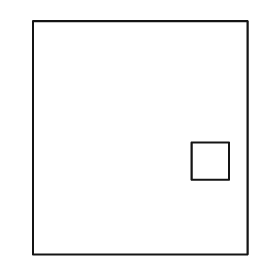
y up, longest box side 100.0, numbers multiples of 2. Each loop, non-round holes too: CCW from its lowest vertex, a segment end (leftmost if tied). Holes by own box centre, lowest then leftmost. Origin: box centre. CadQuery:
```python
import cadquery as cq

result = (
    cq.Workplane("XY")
    .moveTo(-46.0, -50.0)
    .lineTo(46.0, -50.0)
    .lineTo(46.0, 50.0)
    .lineTo(-46.0, 50.0)
    .close()
    .moveTo(22.0, -18.0)
    .lineTo(38.0, -18.0)
    .lineTo(38.0, -2.0)
    .lineTo(22.0, -2.0)
    .close()
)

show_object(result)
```